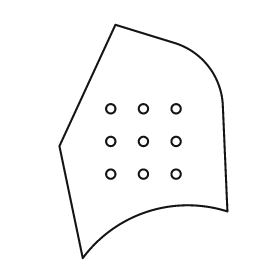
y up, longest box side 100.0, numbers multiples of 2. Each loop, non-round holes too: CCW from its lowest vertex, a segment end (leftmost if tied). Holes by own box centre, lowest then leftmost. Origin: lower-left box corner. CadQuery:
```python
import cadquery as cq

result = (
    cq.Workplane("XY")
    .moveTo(10.0, 0.0)
    .threePointArc((38.0, 20.0), (72.0, 20.0))
    .lineTo(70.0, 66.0)
    .threePointArc((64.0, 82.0), (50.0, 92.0))
    .lineTo(24.0, 100.0)
    .lineTo(0.0, 48.0)
    .close()
    .moveTo(22.0, 36.0)
    .circle(2.0)
    .moveTo(36.0, 36.0)
    .circle(2.0)
    .moveTo(50.0, 36.0)
    .circle(2.0)
    .moveTo(22.0, 50.0)
    .circle(2.0)
    .moveTo(36.0, 50.0)
    .circle(2.0)
    .moveTo(50.0, 50.0)
    .circle(2.0)
    .moveTo(22.0, 64.0)
    .circle(2.0)
    .moveTo(36.0, 64.0)
    .circle(2.0)
    .moveTo(50.0, 64.0)
    .circle(2.0)
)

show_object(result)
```